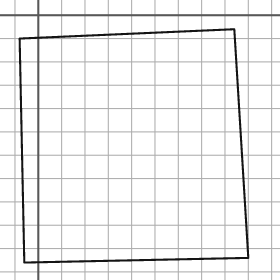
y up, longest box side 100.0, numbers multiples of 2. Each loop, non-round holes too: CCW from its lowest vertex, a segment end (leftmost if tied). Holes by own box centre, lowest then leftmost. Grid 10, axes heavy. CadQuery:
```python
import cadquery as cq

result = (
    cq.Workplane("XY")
    .moveTo(-6.0, -106.0)
    .lineTo(90.0, -104.0)
    .lineTo(84.0, -6.0)
    .lineTo(-8.0, -10.0)
    .close()
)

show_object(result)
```